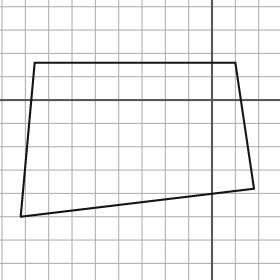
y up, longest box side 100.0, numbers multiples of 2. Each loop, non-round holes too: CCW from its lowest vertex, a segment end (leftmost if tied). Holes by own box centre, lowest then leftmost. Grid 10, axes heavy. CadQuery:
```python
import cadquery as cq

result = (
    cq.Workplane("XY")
    .moveTo(-82.0, -50.0)
    .lineTo(18.0, -38.0)
    .lineTo(10.0, 16.0)
    .lineTo(-76.0, 16.0)
    .close()
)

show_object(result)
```